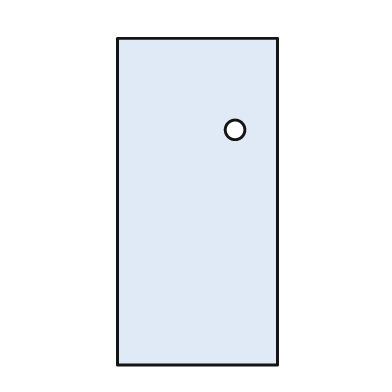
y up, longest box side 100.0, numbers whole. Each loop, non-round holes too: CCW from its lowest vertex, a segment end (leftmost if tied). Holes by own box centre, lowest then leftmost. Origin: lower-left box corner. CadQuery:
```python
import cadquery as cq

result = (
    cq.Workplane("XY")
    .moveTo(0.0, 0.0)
    .lineTo(49.0, 0.0)
    .lineTo(49.0, 100.0)
    .lineTo(0.0, 100.0)
    .close()
    .moveTo(36.0, 72.0)
    .circle(3.0)
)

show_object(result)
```